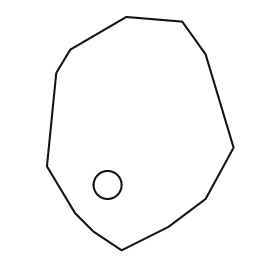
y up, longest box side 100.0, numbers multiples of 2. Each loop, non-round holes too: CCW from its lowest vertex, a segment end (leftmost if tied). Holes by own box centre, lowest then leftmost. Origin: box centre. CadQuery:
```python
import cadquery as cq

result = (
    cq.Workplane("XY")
    .moveTo(-8.0, -50.0)
    .lineTo(12.0, -40.0)
    .lineTo(28.0, -28.0)
    .lineTo(40.0, -6.0)
    .lineTo(28.0, 34.0)
    .lineTo(18.0, 48.0)
    .lineTo(-6.0, 50.0)
    .lineTo(-30.0, 36.0)
    .lineTo(-36.0, 26.0)
    .lineTo(-40.0, -14.0)
    .lineTo(-28.0, -34.0)
    .lineTo(-20.0, -42.0)
    .close()
    .moveTo(-14.0, -22.0)
    .circle(6.0)
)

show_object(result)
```